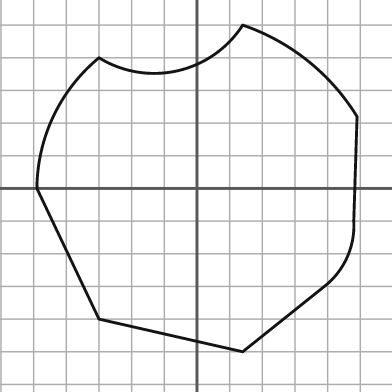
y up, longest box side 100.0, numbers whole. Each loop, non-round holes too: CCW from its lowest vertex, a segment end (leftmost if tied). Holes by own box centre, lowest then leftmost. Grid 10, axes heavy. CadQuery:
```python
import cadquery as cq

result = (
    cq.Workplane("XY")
    .moveTo(14.0, -50.0)
    .lineTo(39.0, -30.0)
    .threePointArc((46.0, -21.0), (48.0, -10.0))
    .lineTo(49.0, 22.0)
    .threePointArc((34.0, 39.0), (14.0, 50.0))
    .threePointArc((-6.0, 36.0), (-30.0, 40.0))
    .threePointArc((-44.0, 22.0), (-49.0, 0.0))
    .lineTo(-30.0, -40.0)
    .close()
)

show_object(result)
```